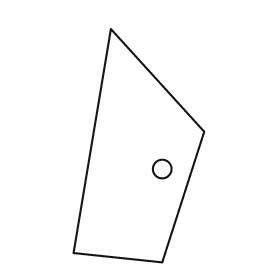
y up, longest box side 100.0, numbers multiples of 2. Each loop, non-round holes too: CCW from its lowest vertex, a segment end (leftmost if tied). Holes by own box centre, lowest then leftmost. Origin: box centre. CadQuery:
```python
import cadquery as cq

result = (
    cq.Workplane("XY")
    .moveTo(10.0, -50.0)
    .lineTo(28.0, 6.0)
    .lineTo(-12.0, 50.0)
    .lineTo(-28.0, -46.0)
    .close()
    .moveTo(10.0, -10.0)
    .circle(4.0)
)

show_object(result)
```